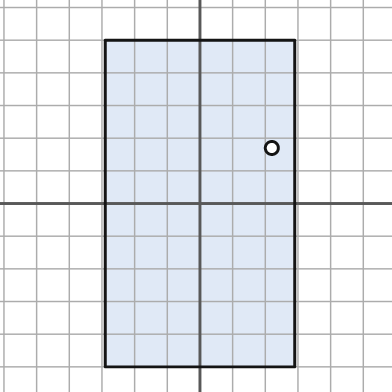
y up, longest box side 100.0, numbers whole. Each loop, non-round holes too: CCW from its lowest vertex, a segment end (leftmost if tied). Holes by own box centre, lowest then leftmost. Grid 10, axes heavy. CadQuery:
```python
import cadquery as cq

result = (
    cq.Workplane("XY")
    .moveTo(-29.0, -50.0)
    .lineTo(29.0, -50.0)
    .lineTo(29.0, 50.0)
    .lineTo(-29.0, 50.0)
    .close()
    .moveTo(22.0, 17.0)
    .circle(2.0)
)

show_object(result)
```